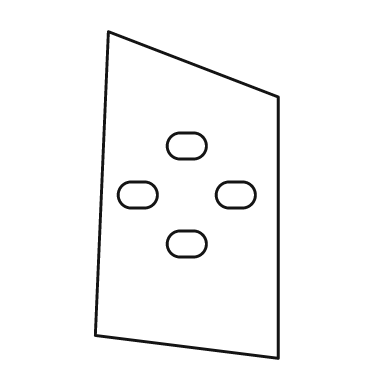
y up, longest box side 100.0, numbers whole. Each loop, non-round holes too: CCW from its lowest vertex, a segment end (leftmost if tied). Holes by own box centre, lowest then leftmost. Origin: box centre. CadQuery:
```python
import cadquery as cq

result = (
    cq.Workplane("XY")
    .moveTo(28.0, -50.0)
    .lineTo(28.0, 30.0)
    .lineTo(-24.0, 50.0)
    .lineTo(-28.0, -43.0)
    .close()
    .moveTo(-2.0, -19.0)
    .lineTo(2.0, -19.0)
    .threePointArc((6.0, -15.0), (2.0, -11.0))
    .lineTo(-2.0, -11.0)
    .threePointArc((-6.0, -15.0), (-2.0, -19.0))
    .close()
    .moveTo(-17.0, -4.0)
    .lineTo(-13.0, -4.0)
    .threePointArc((-9.0, 0.0), (-13.0, 4.0))
    .lineTo(-17.0, 4.0)
    .threePointArc((-21.0, 0.0), (-17.0, -4.0))
    .close()
    .moveTo(13.0, -4.0)
    .lineTo(17.0, -4.0)
    .threePointArc((21.0, 0.0), (17.0, 4.0))
    .lineTo(13.0, 4.0)
    .threePointArc((9.0, 0.0), (13.0, -4.0))
    .close()
    .moveTo(-2.0, 11.0)
    .lineTo(2.0, 11.0)
    .threePointArc((6.0, 15.0), (2.0, 19.0))
    .lineTo(-2.0, 19.0)
    .threePointArc((-6.0, 15.0), (-2.0, 11.0))
    .close()
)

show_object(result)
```